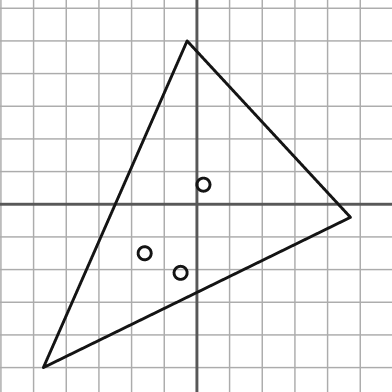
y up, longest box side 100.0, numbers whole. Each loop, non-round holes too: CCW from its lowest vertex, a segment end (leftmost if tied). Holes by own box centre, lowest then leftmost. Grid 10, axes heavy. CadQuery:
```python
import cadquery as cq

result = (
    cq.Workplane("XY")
    .moveTo(-47.0, -50.0)
    .lineTo(47.0, -4.0)
    .lineTo(-3.0, 50.0)
    .close()
    .moveTo(-5.0, -21.0)
    .circle(2.0)
    .moveTo(-16.0, -15.0)
    .circle(2.0)
    .moveTo(2.0, 6.0)
    .circle(2.0)
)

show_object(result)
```